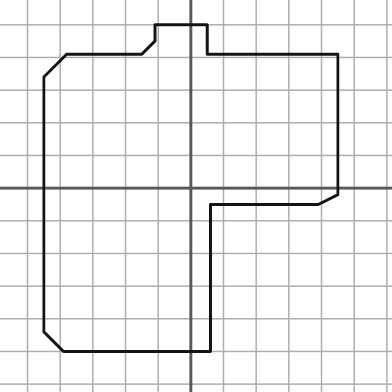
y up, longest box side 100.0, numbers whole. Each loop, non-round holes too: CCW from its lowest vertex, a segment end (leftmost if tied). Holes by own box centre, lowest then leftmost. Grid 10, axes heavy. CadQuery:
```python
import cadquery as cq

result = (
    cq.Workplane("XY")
    .moveTo(-39.0, -50.0)
    .lineTo(6.0, -50.0)
    .lineTo(6.0, -5.0)
    .lineTo(39.0, -5.0)
    .lineTo(45.0, -2.0)
    .lineTo(45.0, 41.0)
    .lineTo(5.0, 41.0)
    .lineTo(5.0, 50.0)
    .lineTo(-11.0, 50.0)
    .lineTo(-11.0, 45.0)
    .lineTo(-15.0, 41.0)
    .lineTo(-38.0, 41.0)
    .lineTo(-45.0, 34.0)
    .lineTo(-45.0, -44.0)
    .close()
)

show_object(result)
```